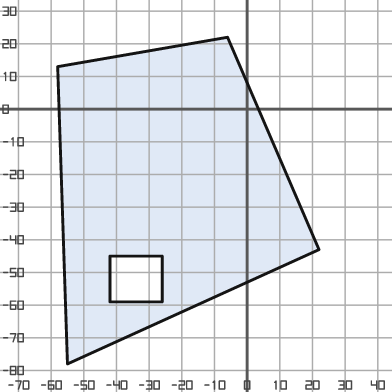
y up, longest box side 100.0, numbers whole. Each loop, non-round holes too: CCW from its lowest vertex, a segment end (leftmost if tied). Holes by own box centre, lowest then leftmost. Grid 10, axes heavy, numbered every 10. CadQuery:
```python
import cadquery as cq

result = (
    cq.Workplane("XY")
    .moveTo(-55.0, -78.0)
    .lineTo(22.0, -43.0)
    .lineTo(-6.0, 22.0)
    .lineTo(-58.0, 13.0)
    .close()
    .moveTo(-42.0, -59.0)
    .lineTo(-26.0, -59.0)
    .lineTo(-26.0, -45.0)
    .lineTo(-42.0, -45.0)
    .close()
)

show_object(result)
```